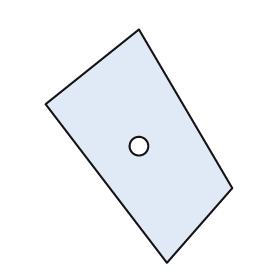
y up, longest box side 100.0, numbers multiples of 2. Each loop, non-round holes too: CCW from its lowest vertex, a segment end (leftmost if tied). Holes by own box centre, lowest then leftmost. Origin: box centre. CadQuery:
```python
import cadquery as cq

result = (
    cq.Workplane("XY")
    .moveTo(12.0, -50.0)
    .lineTo(40.0, -18.0)
    .lineTo(0.0, 50.0)
    .lineTo(-40.0, 18.0)
    .close()
    .moveTo(0.0, 0.0)
    .circle(4.0)
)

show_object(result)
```